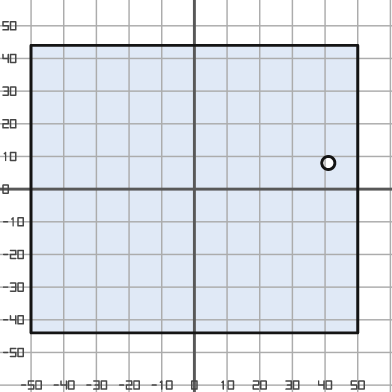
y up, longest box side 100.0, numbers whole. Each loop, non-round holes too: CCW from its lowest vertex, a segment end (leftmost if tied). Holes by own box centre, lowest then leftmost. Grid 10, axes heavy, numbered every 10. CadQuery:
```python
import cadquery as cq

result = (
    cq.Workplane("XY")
    .moveTo(-50.0, -44.0)
    .lineTo(50.0, -44.0)
    .lineTo(50.0, 44.0)
    .lineTo(-50.0, 44.0)
    .close()
    .moveTo(41.0, 8.0)
    .circle(2.0)
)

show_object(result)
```